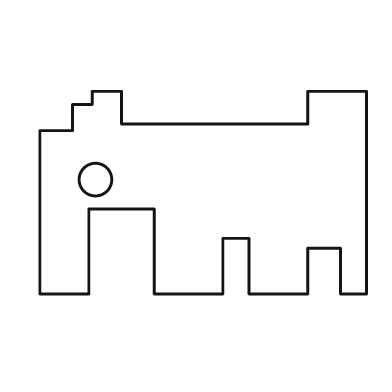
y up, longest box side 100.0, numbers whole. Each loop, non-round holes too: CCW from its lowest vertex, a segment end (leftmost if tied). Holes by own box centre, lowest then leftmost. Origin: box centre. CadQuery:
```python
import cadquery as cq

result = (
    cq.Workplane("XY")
    .moveTo(-50.0, -31.0)
    .lineTo(-35.0, -31.0)
    .lineTo(-35.0, -5.0)
    .lineTo(-15.0, -5.0)
    .lineTo(-15.0, -31.0)
    .lineTo(6.0, -31.0)
    .lineTo(6.0, -14.0)
    .lineTo(14.0, -14.0)
    .lineTo(14.0, -31.0)
    .lineTo(32.0, -31.0)
    .lineTo(32.0, -17.0)
    .lineTo(42.0, -17.0)
    .lineTo(42.0, -31.0)
    .lineTo(50.0, -31.0)
    .lineTo(50.0, 31.0)
    .lineTo(32.0, 31.0)
    .lineTo(32.0, 21.0)
    .lineTo(-25.0, 21.0)
    .lineTo(-25.0, 31.0)
    .lineTo(-34.0, 31.0)
    .lineTo(-34.0, 27.0)
    .lineTo(-40.0, 27.0)
    .lineTo(-40.0, 19.0)
    .lineTo(-50.0, 19.0)
    .close()
    .moveTo(-33.0, 4.0)
    .circle(5.0)
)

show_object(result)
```